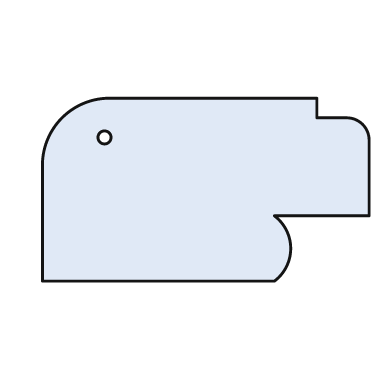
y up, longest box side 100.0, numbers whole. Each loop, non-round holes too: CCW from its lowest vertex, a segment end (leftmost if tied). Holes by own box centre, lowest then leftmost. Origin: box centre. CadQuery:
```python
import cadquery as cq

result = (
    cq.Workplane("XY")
    .moveTo(-50.0, -28.0)
    .lineTo(21.0, -28.0)
    .threePointArc((26.0, -18.0), (21.0, -8.0))
    .lineTo(50.0, -8.0)
    .lineTo(50.0, 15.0)
    .threePointArc((48.0, 20.0), (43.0, 22.0))
    .lineTo(34.0, 22.0)
    .lineTo(34.0, 28.0)
    .lineTo(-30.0, 28.0)
    .threePointArc((-44.0, 22.0), (-50.0, 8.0))
    .close()
    .moveTo(-31.0, 16.0)
    .circle(2.0)
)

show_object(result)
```